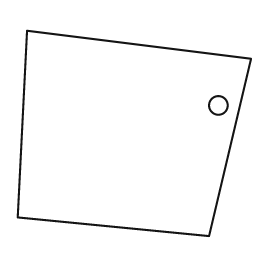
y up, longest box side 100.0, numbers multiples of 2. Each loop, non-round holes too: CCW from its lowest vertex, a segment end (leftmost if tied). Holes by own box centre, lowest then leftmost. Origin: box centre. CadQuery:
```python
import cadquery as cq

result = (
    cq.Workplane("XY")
    .moveTo(32.0, -44.0)
    .lineTo(50.0, 32.0)
    .lineTo(-46.0, 44.0)
    .lineTo(-50.0, -36.0)
    .close()
    .moveTo(36.0, 12.0)
    .circle(4.0)
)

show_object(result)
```